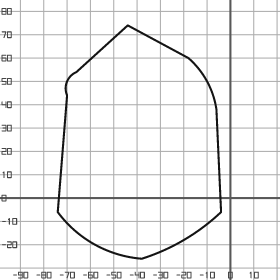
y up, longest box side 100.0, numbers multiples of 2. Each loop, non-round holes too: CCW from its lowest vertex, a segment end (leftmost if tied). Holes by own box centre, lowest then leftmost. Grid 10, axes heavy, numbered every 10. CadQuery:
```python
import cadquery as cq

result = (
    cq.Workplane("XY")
    .moveTo(-38.0, -26.0)
    .threePointArc((-20.0, -18.0), (-4.0, -6.0))
    .lineTo(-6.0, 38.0)
    .threePointArc((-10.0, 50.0), (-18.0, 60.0))
    .lineTo(-44.0, 74.0)
    .lineTo(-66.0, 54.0)
    .threePointArc((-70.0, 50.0), (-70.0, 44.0))
    .lineTo(-74.0, -6.0)
    .threePointArc((-58.0, -20.0), (-38.0, -26.0))
    .close()
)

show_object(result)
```